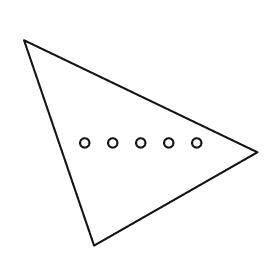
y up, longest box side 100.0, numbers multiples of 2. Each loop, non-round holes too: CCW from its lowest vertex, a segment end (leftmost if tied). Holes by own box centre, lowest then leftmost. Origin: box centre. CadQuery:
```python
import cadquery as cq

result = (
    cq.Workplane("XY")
    .moveTo(-20.0, -44.0)
    .lineTo(50.0, -4.0)
    .lineTo(-50.0, 44.0)
    .close()
    .moveTo(-24.0, 0.0)
    .circle(2.0)
    .moveTo(-12.0, 0.0)
    .circle(2.0)
    .moveTo(0.0, 0.0)
    .circle(2.0)
    .moveTo(12.0, 0.0)
    .circle(2.0)
    .moveTo(24.0, 0.0)
    .circle(2.0)
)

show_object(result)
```